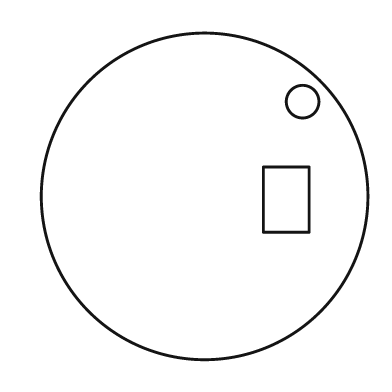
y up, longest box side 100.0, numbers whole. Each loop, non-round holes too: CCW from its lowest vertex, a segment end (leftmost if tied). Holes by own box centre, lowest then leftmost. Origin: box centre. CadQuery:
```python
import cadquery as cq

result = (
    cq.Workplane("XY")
    .moveTo(0.0, 0.0)
    .circle(50.0)
    .moveTo(18.0, -11.0)
    .lineTo(32.0, -11.0)
    .lineTo(32.0, 9.0)
    .lineTo(18.0, 9.0)
    .close()
    .moveTo(30.0, 29.0)
    .circle(5.0)
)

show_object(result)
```